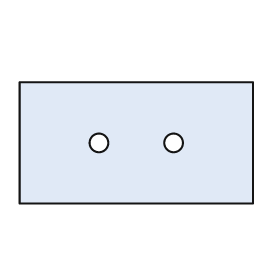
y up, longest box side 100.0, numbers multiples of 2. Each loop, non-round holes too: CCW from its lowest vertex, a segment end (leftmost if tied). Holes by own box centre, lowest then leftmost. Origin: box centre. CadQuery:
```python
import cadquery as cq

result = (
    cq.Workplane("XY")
    .moveTo(-50.0, -26.0)
    .lineTo(50.0, -26.0)
    .lineTo(50.0, 26.0)
    .lineTo(-50.0, 26.0)
    .close()
    .moveTo(-16.0, 0.0)
    .circle(4.0)
    .moveTo(16.0, 0.0)
    .circle(4.0)
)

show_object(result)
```